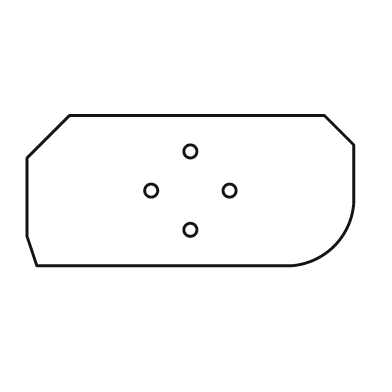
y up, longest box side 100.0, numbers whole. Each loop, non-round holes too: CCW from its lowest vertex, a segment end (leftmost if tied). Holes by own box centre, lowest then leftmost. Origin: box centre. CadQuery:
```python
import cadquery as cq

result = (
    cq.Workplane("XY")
    .moveTo(-47.0, -23.0)
    .lineTo(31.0, -23.0)
    .threePointArc((44.0, -17.0), (50.0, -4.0))
    .lineTo(50.0, 14.0)
    .lineTo(41.0, 23.0)
    .lineTo(-37.0, 23.0)
    .lineTo(-50.0, 10.0)
    .lineTo(-50.0, -14.0)
    .close()
    .moveTo(0.0, -12.0)
    .circle(2.0)
    .moveTo(-12.0, 0.0)
    .circle(2.0)
    .moveTo(12.0, 0.0)
    .circle(2.0)
    .moveTo(0.0, 12.0)
    .circle(2.0)
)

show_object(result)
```